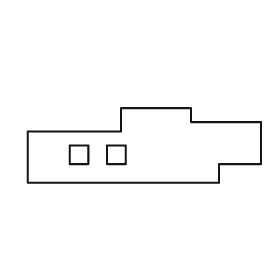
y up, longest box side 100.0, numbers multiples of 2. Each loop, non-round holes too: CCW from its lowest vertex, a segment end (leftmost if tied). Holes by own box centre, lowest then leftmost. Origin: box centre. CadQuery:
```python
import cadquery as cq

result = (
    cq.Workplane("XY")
    .moveTo(-50.0, -16.0)
    .lineTo(32.0, -16.0)
    .lineTo(32.0, -8.0)
    .lineTo(50.0, -8.0)
    .lineTo(50.0, 10.0)
    .lineTo(20.0, 10.0)
    .lineTo(20.0, 16.0)
    .lineTo(-10.0, 16.0)
    .lineTo(-10.0, 6.0)
    .lineTo(-50.0, 6.0)
    .close()
    .moveTo(-32.0, -8.0)
    .lineTo(-24.0, -8.0)
    .lineTo(-24.0, 0.0)
    .lineTo(-32.0, 0.0)
    .close()
    .moveTo(-16.0, -8.0)
    .lineTo(-8.0, -8.0)
    .lineTo(-8.0, 0.0)
    .lineTo(-16.0, 0.0)
    .close()
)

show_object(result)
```